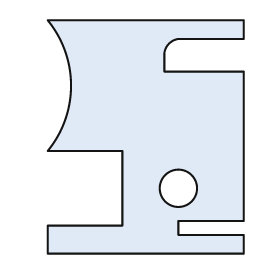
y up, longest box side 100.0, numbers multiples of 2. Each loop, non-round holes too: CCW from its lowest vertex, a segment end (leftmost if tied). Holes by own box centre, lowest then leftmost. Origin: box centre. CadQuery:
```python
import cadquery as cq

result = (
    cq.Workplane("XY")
    .moveTo(-42.0, -50.0)
    .lineTo(42.0, -50.0)
    .lineTo(42.0, -42.0)
    .lineTo(14.0, -42.0)
    .lineTo(14.0, -36.0)
    .lineTo(42.0, -36.0)
    .lineTo(42.0, 28.0)
    .lineTo(8.0, 28.0)
    .lineTo(8.0, 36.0)
    .threePointArc((10.0, 40.0), (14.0, 42.0))
    .lineTo(42.0, 42.0)
    .lineTo(42.0, 50.0)
    .lineTo(-42.0, 50.0)
    .threePointArc((-32.0, 22.0), (-42.0, -6.0))
    .lineTo(-10.0, -6.0)
    .lineTo(-10.0, -38.0)
    .lineTo(-42.0, -38.0)
    .close()
    .moveTo(14.0, -22.0)
    .circle(8.0)
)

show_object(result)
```